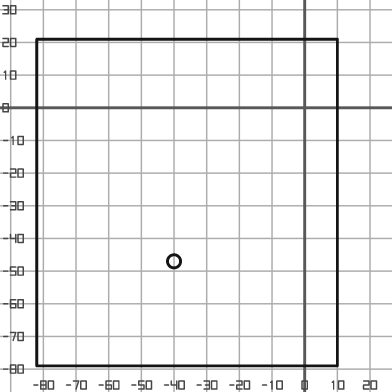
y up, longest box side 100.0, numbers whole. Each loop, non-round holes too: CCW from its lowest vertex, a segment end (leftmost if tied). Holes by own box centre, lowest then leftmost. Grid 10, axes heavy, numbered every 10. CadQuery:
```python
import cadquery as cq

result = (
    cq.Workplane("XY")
    .moveTo(-82.0, -79.0)
    .lineTo(10.0, -79.0)
    .lineTo(10.0, 21.0)
    .lineTo(-82.0, 21.0)
    .close()
    .moveTo(-40.0, -47.0)
    .circle(2.0)
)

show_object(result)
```